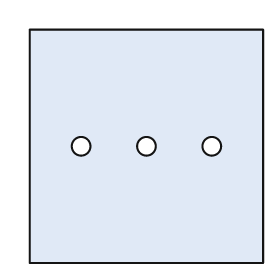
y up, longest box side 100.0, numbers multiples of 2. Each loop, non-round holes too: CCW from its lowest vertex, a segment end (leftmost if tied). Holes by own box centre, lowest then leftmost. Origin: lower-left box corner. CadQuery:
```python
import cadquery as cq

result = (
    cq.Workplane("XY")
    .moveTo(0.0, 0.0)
    .lineTo(100.0, 0.0)
    .lineTo(100.0, 100.0)
    .lineTo(0.0, 100.0)
    .close()
    .moveTo(22.0, 50.0)
    .circle(4.0)
    .moveTo(50.0, 50.0)
    .circle(4.0)
    .moveTo(78.0, 50.0)
    .circle(4.0)
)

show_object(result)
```